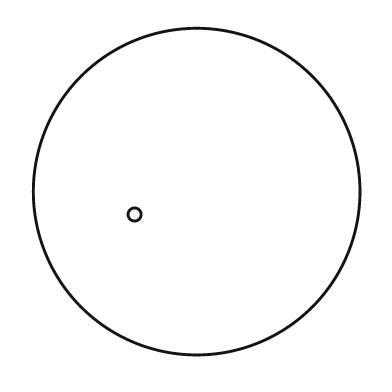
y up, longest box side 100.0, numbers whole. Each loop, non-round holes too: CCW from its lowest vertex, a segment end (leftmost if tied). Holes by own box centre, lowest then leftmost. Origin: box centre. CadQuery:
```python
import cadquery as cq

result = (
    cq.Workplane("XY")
    .moveTo(0.0, 0.0)
    .circle(50.0)
    .moveTo(-19.0, -7.0)
    .circle(2.0)
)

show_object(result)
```